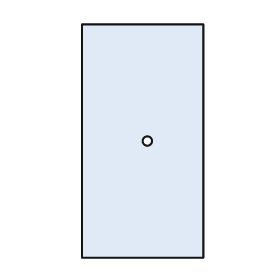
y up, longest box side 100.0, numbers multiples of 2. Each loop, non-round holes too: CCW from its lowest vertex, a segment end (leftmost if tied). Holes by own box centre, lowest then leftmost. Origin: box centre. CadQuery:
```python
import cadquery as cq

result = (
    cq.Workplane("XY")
    .moveTo(-26.0, -50.0)
    .lineTo(26.0, -50.0)
    .lineTo(26.0, 50.0)
    .lineTo(-26.0, 50.0)
    .close()
    .moveTo(2.0, 0.0)
    .circle(2.0)
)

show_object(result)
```